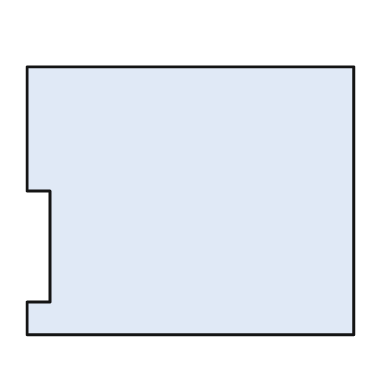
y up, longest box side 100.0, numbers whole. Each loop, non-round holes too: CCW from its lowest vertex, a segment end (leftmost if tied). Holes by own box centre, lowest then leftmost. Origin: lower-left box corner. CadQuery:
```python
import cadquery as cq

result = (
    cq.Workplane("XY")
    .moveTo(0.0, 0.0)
    .lineTo(100.0, 0.0)
    .lineTo(100.0, 82.0)
    .lineTo(0.0, 82.0)
    .lineTo(0.0, 44.0)
    .lineTo(7.0, 44.0)
    .lineTo(7.0, 10.0)
    .lineTo(0.0, 10.0)
    .close()
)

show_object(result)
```